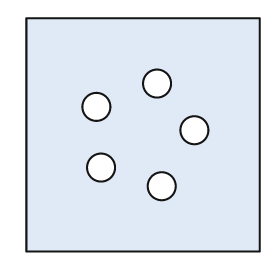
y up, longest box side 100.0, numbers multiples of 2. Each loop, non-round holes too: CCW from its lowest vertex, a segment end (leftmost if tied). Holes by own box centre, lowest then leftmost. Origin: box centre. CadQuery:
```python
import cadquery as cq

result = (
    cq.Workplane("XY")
    .moveTo(-50.0, -50.0)
    .lineTo(50.0, -50.0)
    .lineTo(50.0, 50.0)
    .lineTo(-50.0, 50.0)
    .close()
    .moveTo(8.0, -22.0)
    .circle(6.0)
    .moveTo(-18.0, -14.0)
    .circle(6.0)
    .moveTo(22.0, 2.0)
    .circle(6.0)
    .moveTo(-20.0, 12.0)
    .circle(6.0)
    .moveTo(6.0, 22.0)
    .circle(6.0)
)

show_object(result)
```